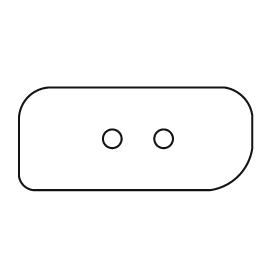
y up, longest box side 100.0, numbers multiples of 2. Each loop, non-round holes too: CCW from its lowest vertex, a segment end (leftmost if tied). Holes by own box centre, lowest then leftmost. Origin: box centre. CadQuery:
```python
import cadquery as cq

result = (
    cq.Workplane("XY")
    .moveTo(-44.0, -22.0)
    .lineTo(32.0, -22.0)
    .threePointArc((44.0, -16.0), (50.0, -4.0))
    .lineTo(50.0, 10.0)
    .threePointArc((46.0, 18.0), (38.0, 22.0))
    .lineTo(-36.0, 22.0)
    .threePointArc((-46.0, 18.0), (-50.0, 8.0))
    .lineTo(-50.0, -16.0)
    .threePointArc((-48.0, -20.0), (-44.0, -22.0))
    .close()
    .moveTo(-10.0, 0.0)
    .circle(4.0)
    .moveTo(12.0, 0.0)
    .circle(4.0)
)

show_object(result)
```